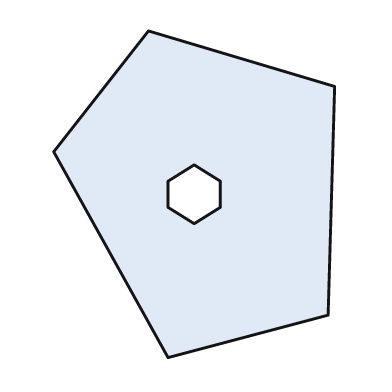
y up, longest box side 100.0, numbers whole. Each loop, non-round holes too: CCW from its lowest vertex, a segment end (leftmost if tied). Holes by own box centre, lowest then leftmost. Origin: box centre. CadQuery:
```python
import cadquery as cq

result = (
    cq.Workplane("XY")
    .moveTo(-8.0, -50.0)
    .lineTo(41.0, -37.0)
    .lineTo(43.0, 33.0)
    .lineTo(-14.0, 50.0)
    .lineTo(-43.0, 13.0)
    .close()
    .moveTo(0.0, -9.0)
    .lineTo(8.0, -4.0)
    .lineTo(8.0, 4.0)
    .lineTo(0.0, 9.0)
    .lineTo(-8.0, 4.0)
    .lineTo(-8.0, -4.0)
    .close()
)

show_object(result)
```